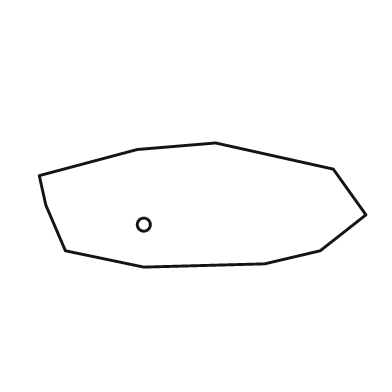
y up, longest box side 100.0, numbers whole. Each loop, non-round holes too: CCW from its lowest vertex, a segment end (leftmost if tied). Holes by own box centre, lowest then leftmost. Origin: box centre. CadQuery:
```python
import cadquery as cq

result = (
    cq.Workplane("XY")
    .moveTo(-18.0, -19.0)
    .lineTo(19.0, -18.0)
    .lineTo(36.0, -14.0)
    .lineTo(50.0, -3.0)
    .lineTo(40.0, 11.0)
    .lineTo(4.0, 19.0)
    .lineTo(-20.0, 17.0)
    .lineTo(-50.0, 9.0)
    .lineTo(-48.0, 0.0)
    .lineTo(-42.0, -14.0)
    .close()
    .moveTo(-18.0, -6.0)
    .circle(2.0)
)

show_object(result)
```